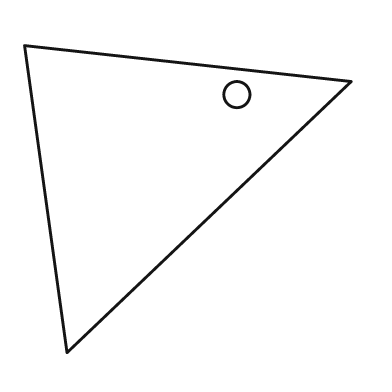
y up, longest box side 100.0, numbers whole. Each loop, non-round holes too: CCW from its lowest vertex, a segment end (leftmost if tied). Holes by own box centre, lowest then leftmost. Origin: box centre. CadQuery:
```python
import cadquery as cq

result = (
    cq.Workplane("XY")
    .moveTo(-37.0, -47.0)
    .lineTo(50.0, 36.0)
    .lineTo(-50.0, 47.0)
    .close()
    .moveTo(15.0, 32.0)
    .circle(4.0)
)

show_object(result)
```